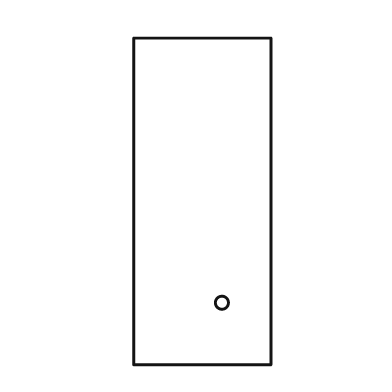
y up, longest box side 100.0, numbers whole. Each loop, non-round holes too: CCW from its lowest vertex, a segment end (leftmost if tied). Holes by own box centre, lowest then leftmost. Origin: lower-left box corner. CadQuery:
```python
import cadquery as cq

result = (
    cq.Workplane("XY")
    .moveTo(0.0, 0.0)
    .lineTo(42.0, 0.0)
    .lineTo(42.0, 100.0)
    .lineTo(0.0, 100.0)
    .close()
    .moveTo(27.0, 19.0)
    .circle(2.0)
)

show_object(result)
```